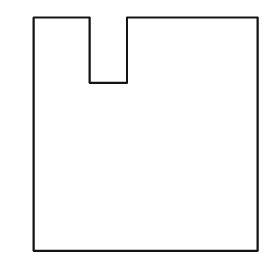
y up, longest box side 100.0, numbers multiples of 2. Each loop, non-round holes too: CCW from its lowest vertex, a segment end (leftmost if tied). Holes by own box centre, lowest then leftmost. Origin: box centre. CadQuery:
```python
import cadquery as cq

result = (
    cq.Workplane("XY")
    .moveTo(-48.0, -50.0)
    .lineTo(48.0, -50.0)
    .lineTo(48.0, 50.0)
    .lineTo(-8.0, 50.0)
    .lineTo(-8.0, 22.0)
    .lineTo(-24.0, 22.0)
    .lineTo(-24.0, 50.0)
    .lineTo(-48.0, 50.0)
    .close()
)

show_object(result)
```